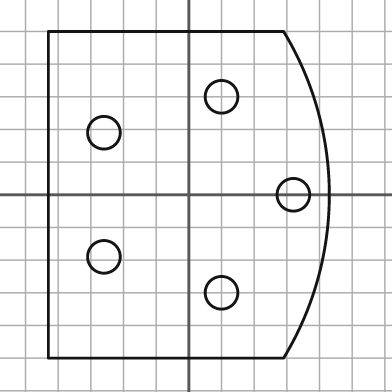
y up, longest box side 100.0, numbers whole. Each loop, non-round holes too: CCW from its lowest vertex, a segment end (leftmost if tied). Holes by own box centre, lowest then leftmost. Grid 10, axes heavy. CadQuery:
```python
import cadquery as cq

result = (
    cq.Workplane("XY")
    .moveTo(-43.0, -50.0)
    .lineTo(29.0, -50.0)
    .threePointArc((43.0, 0.0), (29.0, 50.0))
    .lineTo(-43.0, 50.0)
    .close()
    .moveTo(10.0, -30.0)
    .circle(5.0)
    .moveTo(-26.0, -19.0)
    .circle(5.0)
    .moveTo(32.0, 0.0)
    .circle(5.0)
    .moveTo(-26.0, 19.0)
    .circle(5.0)
    .moveTo(10.0, 30.0)
    .circle(5.0)
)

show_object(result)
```